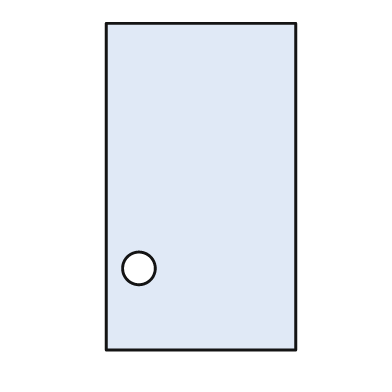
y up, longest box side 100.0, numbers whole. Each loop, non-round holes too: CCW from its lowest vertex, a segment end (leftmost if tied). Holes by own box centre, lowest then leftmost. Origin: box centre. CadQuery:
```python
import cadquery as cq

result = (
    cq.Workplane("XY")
    .moveTo(-29.0, -50.0)
    .lineTo(29.0, -50.0)
    .lineTo(29.0, 50.0)
    .lineTo(-29.0, 50.0)
    .close()
    .moveTo(-19.0, -25.0)
    .circle(5.0)
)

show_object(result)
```